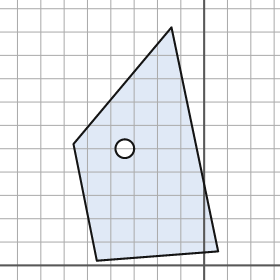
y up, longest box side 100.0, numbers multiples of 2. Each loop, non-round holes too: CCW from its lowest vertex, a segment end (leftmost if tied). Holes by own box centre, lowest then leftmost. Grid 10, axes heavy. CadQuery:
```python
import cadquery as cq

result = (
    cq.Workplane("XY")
    .moveTo(-46.0, 2.0)
    .lineTo(6.0, 6.0)
    .lineTo(-14.0, 102.0)
    .lineTo(-56.0, 52.0)
    .close()
    .moveTo(-34.0, 50.0)
    .circle(4.0)
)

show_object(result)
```